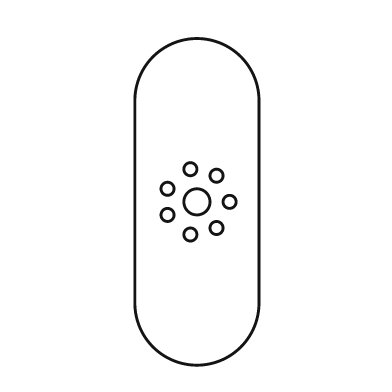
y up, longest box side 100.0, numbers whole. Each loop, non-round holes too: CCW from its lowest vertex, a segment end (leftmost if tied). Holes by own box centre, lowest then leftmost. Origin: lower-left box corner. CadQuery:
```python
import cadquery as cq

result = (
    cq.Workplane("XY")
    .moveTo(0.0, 19.0)
    .threePointArc((19.0, 0.0), (38.0, 19.0))
    .lineTo(38.0, 81.0)
    .threePointArc((19.0, 100.0), (0.0, 81.0))
    .close()
    .moveTo(17.0, 40.0)
    .circle(2.0)
    .moveTo(25.0, 42.0)
    .circle(2.0)
    .moveTo(10.0, 46.0)
    .circle(2.0)
    .moveTo(19.0, 50.0)
    .circle(4.0)
    .moveTo(29.0, 50.0)
    .circle(2.0)
    .moveTo(10.0, 54.0)
    .circle(2.0)
    .moveTo(25.0, 58.0)
    .circle(2.0)
    .moveTo(17.0, 60.0)
    .circle(2.0)
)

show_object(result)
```